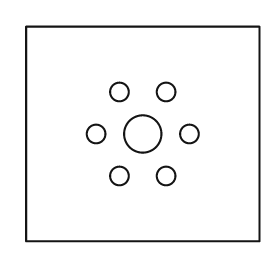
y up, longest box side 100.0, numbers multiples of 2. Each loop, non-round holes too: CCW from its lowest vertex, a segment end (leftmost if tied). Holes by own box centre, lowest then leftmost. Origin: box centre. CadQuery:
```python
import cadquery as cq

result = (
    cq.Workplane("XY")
    .moveTo(-50.0, -46.0)
    .lineTo(50.0, -46.0)
    .lineTo(50.0, 46.0)
    .lineTo(-50.0, 46.0)
    .close()
    .moveTo(-10.0, -18.0)
    .circle(4.0)
    .moveTo(10.0, -18.0)
    .circle(4.0)
    .moveTo(-20.0, 0.0)
    .circle(4.0)
    .moveTo(0.0, 0.0)
    .circle(8.0)
    .moveTo(20.0, 0.0)
    .circle(4.0)
    .moveTo(-10.0, 18.0)
    .circle(4.0)
    .moveTo(10.0, 18.0)
    .circle(4.0)
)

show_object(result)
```